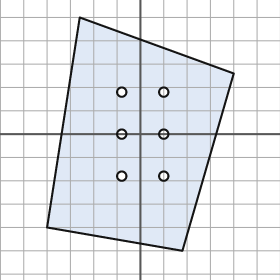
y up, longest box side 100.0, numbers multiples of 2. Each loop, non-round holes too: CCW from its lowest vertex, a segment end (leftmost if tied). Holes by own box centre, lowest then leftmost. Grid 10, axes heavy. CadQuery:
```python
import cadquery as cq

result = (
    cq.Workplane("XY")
    .moveTo(18.0, -50.0)
    .lineTo(40.0, 26.0)
    .lineTo(-26.0, 50.0)
    .lineTo(-40.0, -40.0)
    .close()
    .moveTo(-8.0, -18.0)
    .circle(2.0)
    .moveTo(10.0, -18.0)
    .circle(2.0)
    .moveTo(-8.0, 0.0)
    .circle(2.0)
    .moveTo(10.0, 0.0)
    .circle(2.0)
    .moveTo(-8.0, 18.0)
    .circle(2.0)
    .moveTo(10.0, 18.0)
    .circle(2.0)
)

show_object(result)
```